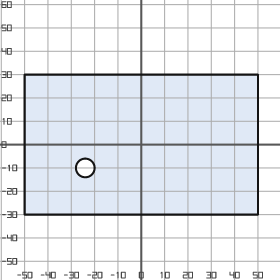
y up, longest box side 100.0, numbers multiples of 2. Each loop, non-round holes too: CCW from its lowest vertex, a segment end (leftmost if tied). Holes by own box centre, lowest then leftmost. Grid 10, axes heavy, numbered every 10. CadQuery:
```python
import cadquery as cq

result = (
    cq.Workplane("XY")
    .moveTo(-50.0, -30.0)
    .lineTo(50.0, -30.0)
    .lineTo(50.0, 30.0)
    .lineTo(-50.0, 30.0)
    .close()
    .moveTo(-24.0, -10.0)
    .circle(4.0)
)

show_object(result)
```